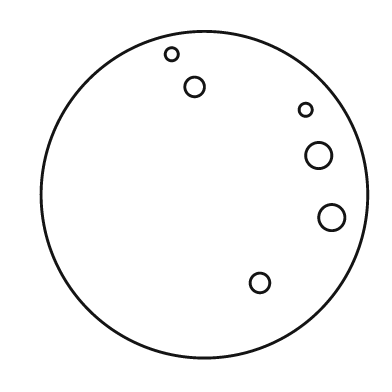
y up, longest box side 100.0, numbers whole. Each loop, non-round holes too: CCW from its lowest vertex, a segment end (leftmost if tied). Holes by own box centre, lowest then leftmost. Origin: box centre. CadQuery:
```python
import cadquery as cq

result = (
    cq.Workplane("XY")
    .moveTo(0.0, 0.0)
    .circle(50.0)
    .moveTo(17.0, -27.0)
    .circle(3.0)
    .moveTo(39.0, -7.0)
    .circle(4.0)
    .moveTo(35.0, 12.0)
    .circle(4.0)
    .moveTo(31.0, 26.0)
    .circle(2.0)
    .moveTo(-3.0, 33.0)
    .circle(3.0)
    .moveTo(-10.0, 43.0)
    .circle(2.0)
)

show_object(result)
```